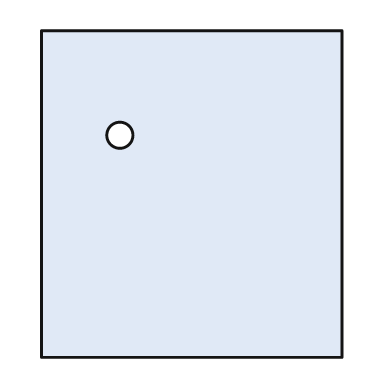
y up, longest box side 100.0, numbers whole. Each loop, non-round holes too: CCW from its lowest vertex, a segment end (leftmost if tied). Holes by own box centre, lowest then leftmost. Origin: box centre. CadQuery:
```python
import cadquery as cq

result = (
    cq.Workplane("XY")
    .moveTo(-46.0, -50.0)
    .lineTo(46.0, -50.0)
    .lineTo(46.0, 50.0)
    .lineTo(-46.0, 50.0)
    .close()
    .moveTo(-22.0, 18.0)
    .circle(4.0)
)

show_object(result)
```